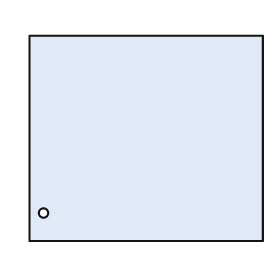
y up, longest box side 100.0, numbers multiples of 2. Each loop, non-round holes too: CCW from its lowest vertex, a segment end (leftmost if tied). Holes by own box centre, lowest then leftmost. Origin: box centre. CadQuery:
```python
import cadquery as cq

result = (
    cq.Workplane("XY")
    .moveTo(-50.0, -44.0)
    .lineTo(50.0, -44.0)
    .lineTo(50.0, 44.0)
    .lineTo(-50.0, 44.0)
    .close()
    .moveTo(-44.0, -32.0)
    .circle(2.0)
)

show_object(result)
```